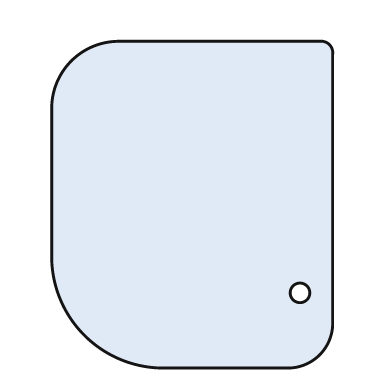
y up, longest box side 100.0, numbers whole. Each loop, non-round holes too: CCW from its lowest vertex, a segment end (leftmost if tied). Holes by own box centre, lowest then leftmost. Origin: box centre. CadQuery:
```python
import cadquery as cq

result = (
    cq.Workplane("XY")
    .moveTo(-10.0, -50.0)
    .lineTo(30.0, -50.0)
    .threePointArc((39.0, -46.0), (43.0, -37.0))
    .lineTo(43.0, 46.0)
    .threePointArc((42.0, 49.0), (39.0, 50.0))
    .lineTo(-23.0, 50.0)
    .threePointArc((-37.0, 44.0), (-43.0, 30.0))
    .lineTo(-43.0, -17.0)
    .threePointArc((-33.0, -40.0), (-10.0, -50.0))
    .close()
    .moveTo(33.0, -27.0)
    .circle(3.0)
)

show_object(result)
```